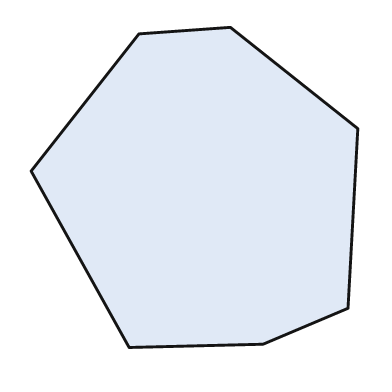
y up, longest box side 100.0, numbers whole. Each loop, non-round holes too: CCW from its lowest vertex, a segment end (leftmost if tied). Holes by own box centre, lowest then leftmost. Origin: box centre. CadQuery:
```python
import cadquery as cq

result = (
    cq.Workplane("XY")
    .moveTo(-20.0, -49.0)
    .lineTo(21.0, -48.0)
    .lineTo(47.0, -37.0)
    .lineTo(50.0, 18.0)
    .lineTo(11.0, 49.0)
    .lineTo(-17.0, 47.0)
    .lineTo(-50.0, 5.0)
    .close()
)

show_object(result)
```